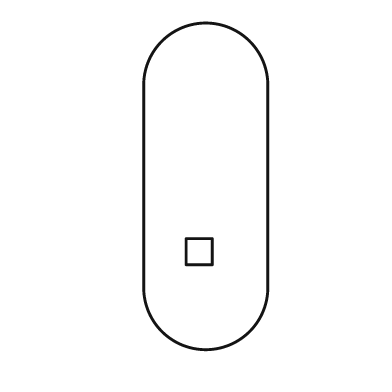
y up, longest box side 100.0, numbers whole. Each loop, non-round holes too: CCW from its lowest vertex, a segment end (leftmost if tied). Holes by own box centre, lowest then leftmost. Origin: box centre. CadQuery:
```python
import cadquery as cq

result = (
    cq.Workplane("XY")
    .moveTo(-19.0, -31.0)
    .threePointArc((0.0, -50.0), (19.0, -31.0))
    .lineTo(19.0, 31.0)
    .threePointArc((0.0, 50.0), (-19.0, 31.0))
    .close()
    .moveTo(-6.0, -24.0)
    .lineTo(2.0, -24.0)
    .lineTo(2.0, -16.0)
    .lineTo(-6.0, -16.0)
    .close()
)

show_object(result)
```